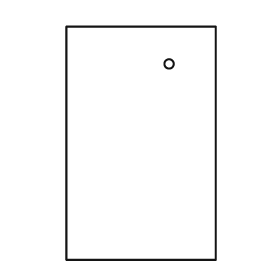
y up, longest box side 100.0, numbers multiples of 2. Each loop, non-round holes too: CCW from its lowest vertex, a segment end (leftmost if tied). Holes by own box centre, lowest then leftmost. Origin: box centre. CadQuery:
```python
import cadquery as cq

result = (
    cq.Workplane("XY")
    .moveTo(-32.0, -50.0)
    .lineTo(32.0, -50.0)
    .lineTo(32.0, 50.0)
    .lineTo(-32.0, 50.0)
    .close()
    .moveTo(12.0, 34.0)
    .circle(2.0)
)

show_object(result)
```